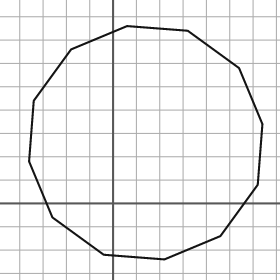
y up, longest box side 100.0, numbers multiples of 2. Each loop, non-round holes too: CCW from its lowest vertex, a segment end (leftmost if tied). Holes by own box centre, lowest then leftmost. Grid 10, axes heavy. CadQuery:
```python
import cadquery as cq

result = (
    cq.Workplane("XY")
    .moveTo(22.0, -24.0)
    .lineTo(46.0, -14.0)
    .lineTo(62.0, 8.0)
    .lineTo(64.0, 34.0)
    .lineTo(54.0, 58.0)
    .lineTo(32.0, 74.0)
    .lineTo(6.0, 76.0)
    .lineTo(-18.0, 66.0)
    .lineTo(-34.0, 44.0)
    .lineTo(-36.0, 18.0)
    .lineTo(-26.0, -6.0)
    .lineTo(-4.0, -22.0)
    .close()
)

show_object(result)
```